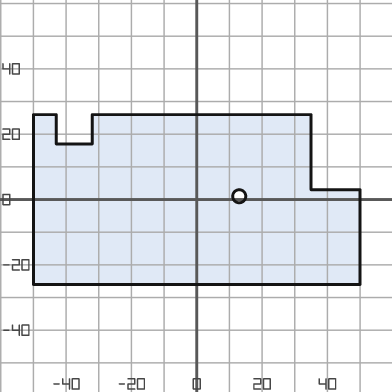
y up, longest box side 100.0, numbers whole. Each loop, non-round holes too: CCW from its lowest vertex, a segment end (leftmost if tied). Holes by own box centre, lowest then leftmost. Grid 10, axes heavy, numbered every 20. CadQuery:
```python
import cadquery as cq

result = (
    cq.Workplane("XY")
    .moveTo(-50.0, -26.0)
    .lineTo(50.0, -26.0)
    .lineTo(50.0, 3.0)
    .lineTo(35.0, 3.0)
    .lineTo(35.0, 26.0)
    .lineTo(-32.0, 26.0)
    .lineTo(-32.0, 17.0)
    .lineTo(-43.0, 17.0)
    .lineTo(-43.0, 26.0)
    .lineTo(-50.0, 26.0)
    .close()
    .moveTo(13.0, 1.0)
    .circle(2.0)
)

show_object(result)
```